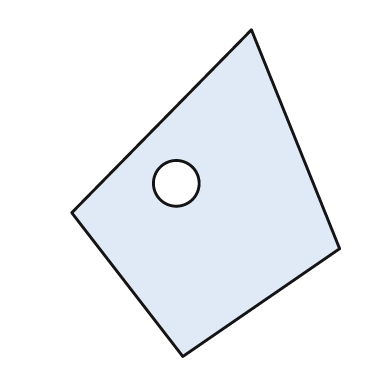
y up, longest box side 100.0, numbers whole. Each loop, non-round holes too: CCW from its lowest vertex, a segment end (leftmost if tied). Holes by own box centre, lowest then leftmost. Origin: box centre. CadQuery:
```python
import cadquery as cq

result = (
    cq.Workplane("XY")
    .moveTo(-7.0, -50.0)
    .lineTo(41.0, -17.0)
    .lineTo(14.0, 50.0)
    .lineTo(-41.0, -6.0)
    .close()
    .moveTo(-9.0, 3.0)
    .circle(7.0)
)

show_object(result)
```